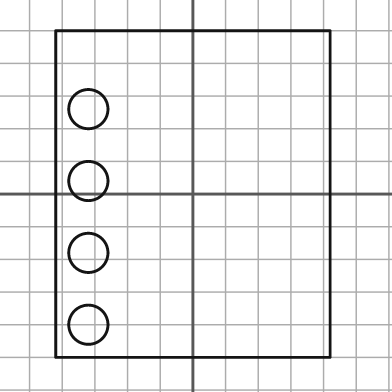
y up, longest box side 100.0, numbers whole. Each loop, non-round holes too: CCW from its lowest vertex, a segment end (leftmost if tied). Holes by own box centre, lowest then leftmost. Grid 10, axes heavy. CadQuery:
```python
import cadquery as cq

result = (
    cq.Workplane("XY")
    .moveTo(-42.0, -50.0)
    .lineTo(42.0, -50.0)
    .lineTo(42.0, 50.0)
    .lineTo(-42.0, 50.0)
    .close()
    .moveTo(-32.0, -40.0)
    .circle(6.0)
    .moveTo(-32.0, -18.0)
    .circle(6.0)
    .moveTo(-32.0, 4.0)
    .circle(6.0)
    .moveTo(-32.0, 26.0)
    .circle(6.0)
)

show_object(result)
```